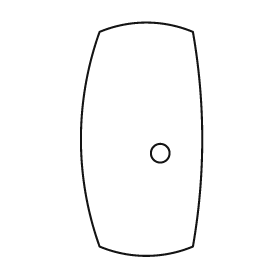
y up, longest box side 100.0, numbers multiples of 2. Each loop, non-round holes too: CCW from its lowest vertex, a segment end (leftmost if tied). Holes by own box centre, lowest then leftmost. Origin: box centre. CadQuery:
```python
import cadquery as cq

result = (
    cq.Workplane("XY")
    .moveTo(-18.0, -46.0)
    .threePointArc((2.0, -50.0), (22.0, -46.0))
    .threePointArc((26.0, 0.0), (22.0, 46.0))
    .threePointArc((2.0, 50.0), (-18.0, 46.0))
    .threePointArc((-26.0, 0.0), (-18.0, -46.0))
    .close()
    .moveTo(8.0, -6.0)
    .circle(4.0)
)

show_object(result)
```